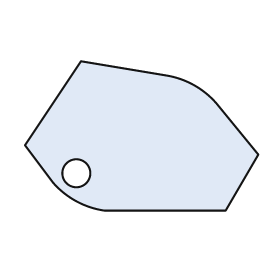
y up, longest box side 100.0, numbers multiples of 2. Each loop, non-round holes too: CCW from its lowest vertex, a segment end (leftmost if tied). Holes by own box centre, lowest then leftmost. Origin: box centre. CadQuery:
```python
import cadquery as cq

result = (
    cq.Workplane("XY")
    .moveTo(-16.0, -32.0)
    .lineTo(36.0, -32.0)
    .lineTo(50.0, -8.0)
    .lineTo(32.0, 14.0)
    .threePointArc((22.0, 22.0), (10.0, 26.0))
    .lineTo(-26.0, 32.0)
    .lineTo(-50.0, -4.0)
    .lineTo(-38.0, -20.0)
    .threePointArc((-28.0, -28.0), (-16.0, -32.0))
    .close()
    .moveTo(-28.0, -16.0)
    .circle(6.0)
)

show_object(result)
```